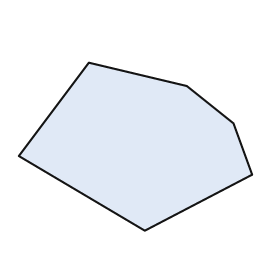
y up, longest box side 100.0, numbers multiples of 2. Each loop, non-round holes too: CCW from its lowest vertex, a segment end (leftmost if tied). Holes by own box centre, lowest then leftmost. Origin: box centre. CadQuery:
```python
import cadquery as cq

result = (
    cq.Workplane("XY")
    .moveTo(4.0, -36.0)
    .lineTo(50.0, -12.0)
    .lineTo(42.0, 10.0)
    .lineTo(22.0, 26.0)
    .lineTo(-20.0, 36.0)
    .lineTo(-50.0, -4.0)
    .close()
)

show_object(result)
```